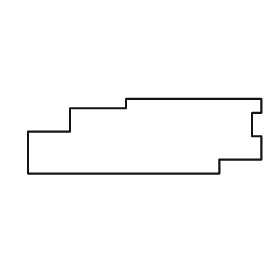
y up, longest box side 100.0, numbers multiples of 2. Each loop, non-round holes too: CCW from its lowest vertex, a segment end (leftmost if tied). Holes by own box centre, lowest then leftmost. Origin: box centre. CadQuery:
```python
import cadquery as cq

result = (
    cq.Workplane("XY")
    .moveTo(-50.0, -16.0)
    .lineTo(32.0, -16.0)
    .lineTo(32.0, -10.0)
    .lineTo(50.0, -10.0)
    .lineTo(50.0, 0.0)
    .lineTo(46.0, 0.0)
    .lineTo(46.0, 10.0)
    .lineTo(50.0, 10.0)
    .lineTo(50.0, 16.0)
    .lineTo(-8.0, 16.0)
    .lineTo(-8.0, 12.0)
    .lineTo(-32.0, 12.0)
    .lineTo(-32.0, 2.0)
    .lineTo(-50.0, 2.0)
    .close()
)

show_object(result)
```